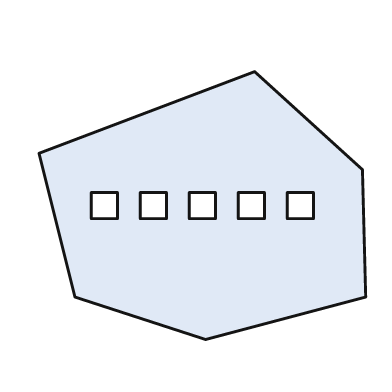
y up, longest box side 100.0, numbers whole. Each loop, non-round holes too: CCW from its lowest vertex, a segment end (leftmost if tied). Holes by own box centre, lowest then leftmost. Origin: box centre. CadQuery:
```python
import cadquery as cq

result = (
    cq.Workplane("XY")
    .moveTo(1.0, -41.0)
    .lineTo(50.0, -28.0)
    .lineTo(49.0, 11.0)
    .lineTo(16.0, 41.0)
    .lineTo(-50.0, 16.0)
    .lineTo(-39.0, -28.0)
    .close()
    .moveTo(-34.0, -4.0)
    .lineTo(-26.0, -4.0)
    .lineTo(-26.0, 4.0)
    .lineTo(-34.0, 4.0)
    .close()
    .moveTo(-19.0, -4.0)
    .lineTo(-11.0, -4.0)
    .lineTo(-11.0, 4.0)
    .lineTo(-19.0, 4.0)
    .close()
    .moveTo(-4.0, -4.0)
    .lineTo(4.0, -4.0)
    .lineTo(4.0, 4.0)
    .lineTo(-4.0, 4.0)
    .close()
    .moveTo(11.0, -4.0)
    .lineTo(19.0, -4.0)
    .lineTo(19.0, 4.0)
    .lineTo(11.0, 4.0)
    .close()
    .moveTo(26.0, -4.0)
    .lineTo(34.0, -4.0)
    .lineTo(34.0, 4.0)
    .lineTo(26.0, 4.0)
    .close()
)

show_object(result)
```